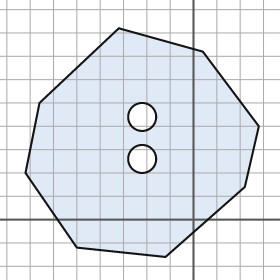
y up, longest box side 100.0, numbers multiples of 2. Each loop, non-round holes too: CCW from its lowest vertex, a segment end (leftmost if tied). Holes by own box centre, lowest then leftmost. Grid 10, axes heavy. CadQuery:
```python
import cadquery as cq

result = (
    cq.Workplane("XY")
    .moveTo(-12.0, -16.0)
    .lineTo(22.0, 14.0)
    .lineTo(28.0, 40.0)
    .lineTo(4.0, 72.0)
    .lineTo(-32.0, 82.0)
    .lineTo(-66.0, 50.0)
    .lineTo(-72.0, 20.0)
    .lineTo(-50.0, -12.0)
    .close()
    .moveTo(-22.0, 26.0)
    .circle(6.0)
    .moveTo(-22.0, 44.0)
    .circle(6.0)
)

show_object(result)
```